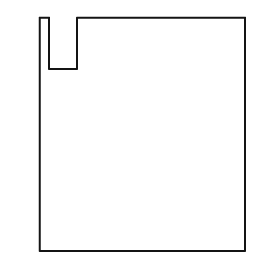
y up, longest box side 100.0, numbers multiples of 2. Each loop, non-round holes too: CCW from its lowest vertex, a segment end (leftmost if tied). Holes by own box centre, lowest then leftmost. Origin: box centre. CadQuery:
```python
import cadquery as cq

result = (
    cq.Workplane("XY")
    .moveTo(-44.0, -50.0)
    .lineTo(44.0, -50.0)
    .lineTo(44.0, 50.0)
    .lineTo(-28.0, 50.0)
    .lineTo(-28.0, 28.0)
    .lineTo(-40.0, 28.0)
    .lineTo(-40.0, 50.0)
    .lineTo(-44.0, 50.0)
    .close()
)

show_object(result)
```